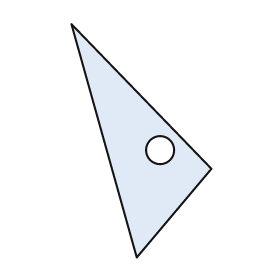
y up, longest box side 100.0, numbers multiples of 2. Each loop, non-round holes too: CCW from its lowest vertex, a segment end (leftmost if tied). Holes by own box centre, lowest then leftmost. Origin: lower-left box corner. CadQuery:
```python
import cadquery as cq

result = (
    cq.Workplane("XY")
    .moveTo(28.0, 0.0)
    .lineTo(60.0, 38.0)
    .lineTo(0.0, 100.0)
    .close()
    .moveTo(38.0, 46.0)
    .circle(6.0)
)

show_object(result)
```